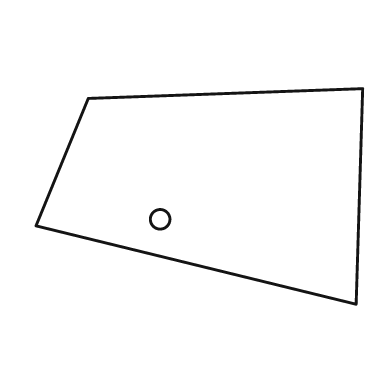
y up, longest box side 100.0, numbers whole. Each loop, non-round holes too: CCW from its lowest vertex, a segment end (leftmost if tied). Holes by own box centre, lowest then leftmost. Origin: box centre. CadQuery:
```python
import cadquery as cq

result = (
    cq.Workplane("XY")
    .moveTo(48.0, -33.0)
    .lineTo(50.0, 33.0)
    .lineTo(-34.0, 30.0)
    .lineTo(-50.0, -9.0)
    .close()
    .moveTo(-12.0, -7.0)
    .circle(3.0)
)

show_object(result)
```